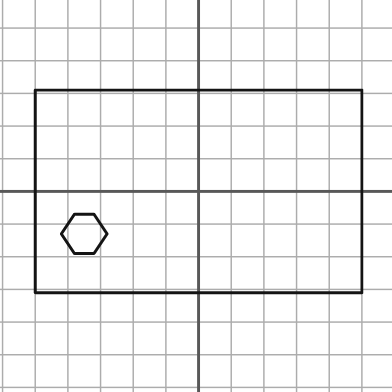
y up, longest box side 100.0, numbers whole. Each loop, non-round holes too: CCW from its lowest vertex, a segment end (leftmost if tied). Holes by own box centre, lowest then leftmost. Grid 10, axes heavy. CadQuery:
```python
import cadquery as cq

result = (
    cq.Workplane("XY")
    .moveTo(-50.0, -31.0)
    .lineTo(50.0, -31.0)
    .lineTo(50.0, 31.0)
    .lineTo(-50.0, 31.0)
    .close()
    .moveTo(-38.0, -19.0)
    .lineTo(-32.0, -19.0)
    .lineTo(-28.0, -13.0)
    .lineTo(-32.0, -7.0)
    .lineTo(-38.0, -7.0)
    .lineTo(-42.0, -13.0)
    .close()
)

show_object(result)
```